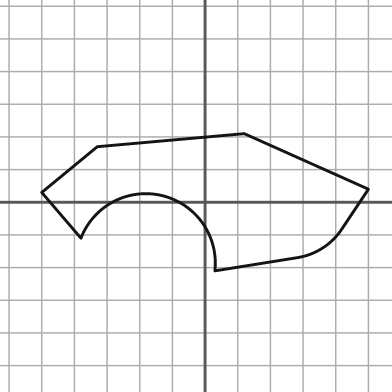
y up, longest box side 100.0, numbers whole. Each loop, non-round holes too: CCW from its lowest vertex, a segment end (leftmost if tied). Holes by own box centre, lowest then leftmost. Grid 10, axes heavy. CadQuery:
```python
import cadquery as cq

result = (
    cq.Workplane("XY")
    .moveTo(3.0, -21.0)
    .lineTo(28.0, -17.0)
    .threePointArc((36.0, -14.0), (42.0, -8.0))
    .lineTo(50.0, 4.0)
    .lineTo(12.0, 21.0)
    .lineTo(-33.0, 17.0)
    .lineTo(-50.0, 3.0)
    .lineTo(-38.0, -11.0)
    .threePointArc((-13.0, 2.0), (3.0, -21.0))
    .close()
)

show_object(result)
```